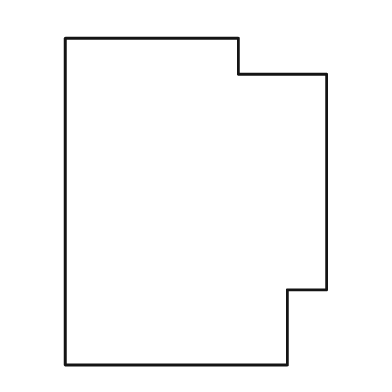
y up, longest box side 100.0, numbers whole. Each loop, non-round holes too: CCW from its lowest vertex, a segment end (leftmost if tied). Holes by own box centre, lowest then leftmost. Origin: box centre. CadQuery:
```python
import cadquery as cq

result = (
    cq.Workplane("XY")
    .moveTo(-40.0, -50.0)
    .lineTo(28.0, -50.0)
    .lineTo(28.0, -27.0)
    .lineTo(40.0, -27.0)
    .lineTo(40.0, 39.0)
    .lineTo(13.0, 39.0)
    .lineTo(13.0, 50.0)
    .lineTo(-40.0, 50.0)
    .close()
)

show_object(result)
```